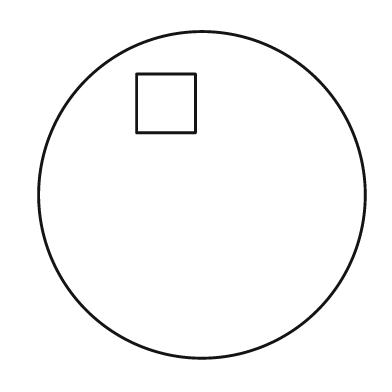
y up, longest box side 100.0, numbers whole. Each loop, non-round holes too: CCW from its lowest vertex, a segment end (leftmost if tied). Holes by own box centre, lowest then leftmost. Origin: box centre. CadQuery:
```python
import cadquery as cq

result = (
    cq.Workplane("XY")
    .moveTo(0.0, 0.0)
    .circle(50.0)
    .moveTo(-20.0, 19.0)
    .lineTo(-2.0, 19.0)
    .lineTo(-2.0, 37.0)
    .lineTo(-20.0, 37.0)
    .close()
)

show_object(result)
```